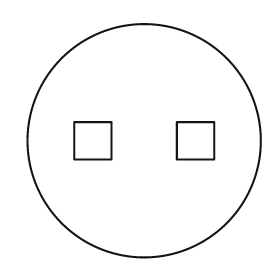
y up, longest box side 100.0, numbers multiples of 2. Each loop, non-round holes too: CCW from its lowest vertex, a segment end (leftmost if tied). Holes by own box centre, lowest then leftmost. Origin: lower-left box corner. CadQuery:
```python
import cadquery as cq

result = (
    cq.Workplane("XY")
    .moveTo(50.0, 50.0)
    .circle(50.0)
    .moveTo(20.0, 42.0)
    .lineTo(36.0, 42.0)
    .lineTo(36.0, 58.0)
    .lineTo(20.0, 58.0)
    .close()
    .moveTo(64.0, 42.0)
    .lineTo(80.0, 42.0)
    .lineTo(80.0, 58.0)
    .lineTo(64.0, 58.0)
    .close()
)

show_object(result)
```